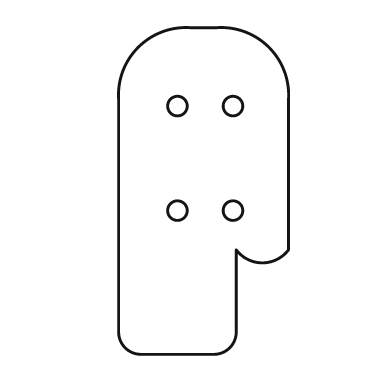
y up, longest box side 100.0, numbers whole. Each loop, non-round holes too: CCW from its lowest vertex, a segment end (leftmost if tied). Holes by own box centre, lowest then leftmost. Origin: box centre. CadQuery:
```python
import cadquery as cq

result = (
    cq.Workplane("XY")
    .moveTo(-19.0, -50.0)
    .lineTo(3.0, -50.0)
    .threePointArc((8.0, -48.0), (10.0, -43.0))
    .lineTo(10.0, -18.0)
    .threePointArc((18.0, -22.0), (26.0, -18.0))
    .lineTo(26.0, 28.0)
    .threePointArc((20.0, 44.0), (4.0, 50.0))
    .lineTo(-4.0, 50.0)
    .threePointArc((-20.0, 44.0), (-26.0, 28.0))
    .lineTo(-26.0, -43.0)
    .threePointArc((-24.0, -48.0), (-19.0, -50.0))
    .close()
    .moveTo(-8.0, -6.0)
    .circle(3.0)
    .moveTo(9.0, -6.0)
    .circle(3.0)
    .moveTo(-8.0, 26.0)
    .circle(3.0)
    .moveTo(9.0, 26.0)
    .circle(3.0)
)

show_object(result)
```